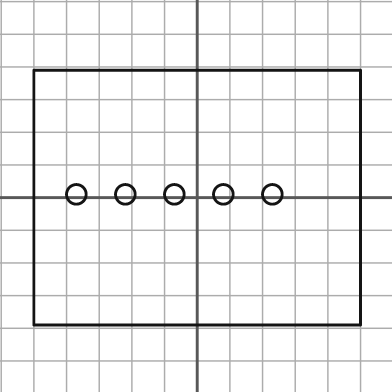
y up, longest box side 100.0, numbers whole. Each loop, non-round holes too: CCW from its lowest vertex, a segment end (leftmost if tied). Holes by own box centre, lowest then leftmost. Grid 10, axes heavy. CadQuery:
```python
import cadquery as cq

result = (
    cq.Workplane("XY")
    .moveTo(-50.0, -39.0)
    .lineTo(50.0, -39.0)
    .lineTo(50.0, 39.0)
    .lineTo(-50.0, 39.0)
    .close()
    .moveTo(-37.0, 1.0)
    .circle(3.0)
    .moveTo(-22.0, 1.0)
    .circle(3.0)
    .moveTo(-7.0, 1.0)
    .circle(3.0)
    .moveTo(8.0, 1.0)
    .circle(3.0)
    .moveTo(23.0, 1.0)
    .circle(3.0)
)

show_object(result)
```